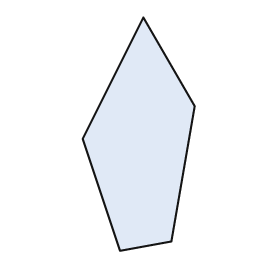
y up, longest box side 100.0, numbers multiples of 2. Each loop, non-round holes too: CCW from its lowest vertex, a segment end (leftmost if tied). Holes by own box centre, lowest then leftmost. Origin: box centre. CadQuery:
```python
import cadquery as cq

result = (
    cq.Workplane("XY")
    .moveTo(-8.0, -50.0)
    .lineTo(14.0, -46.0)
    .lineTo(24.0, 12.0)
    .lineTo(2.0, 50.0)
    .lineTo(-24.0, -2.0)
    .close()
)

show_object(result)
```